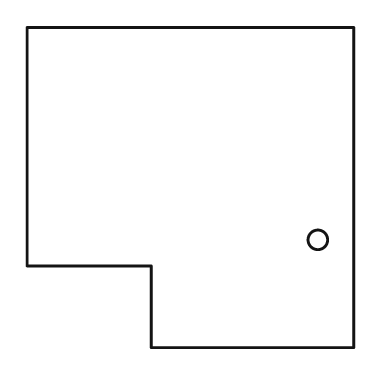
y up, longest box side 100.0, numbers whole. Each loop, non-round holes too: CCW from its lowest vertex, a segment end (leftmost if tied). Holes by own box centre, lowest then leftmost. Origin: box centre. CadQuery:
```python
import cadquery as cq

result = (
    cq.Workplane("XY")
    .moveTo(-12.0, -49.0)
    .lineTo(50.0, -49.0)
    .lineTo(50.0, 49.0)
    .lineTo(-50.0, 49.0)
    .lineTo(-50.0, -24.0)
    .lineTo(-12.0, -24.0)
    .close()
    .moveTo(39.0, -16.0)
    .circle(3.0)
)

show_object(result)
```